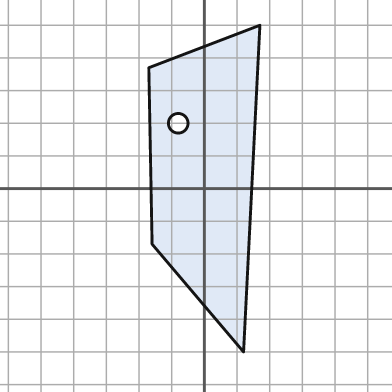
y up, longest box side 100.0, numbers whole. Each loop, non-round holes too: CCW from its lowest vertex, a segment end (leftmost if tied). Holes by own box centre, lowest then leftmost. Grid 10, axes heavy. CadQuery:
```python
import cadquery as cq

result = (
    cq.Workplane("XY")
    .moveTo(12.0, -50.0)
    .lineTo(17.0, 50.0)
    .lineTo(-17.0, 37.0)
    .lineTo(-16.0, -17.0)
    .close()
    .moveTo(-8.0, 20.0)
    .circle(3.0)
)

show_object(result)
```